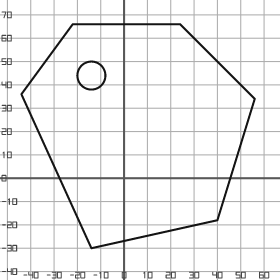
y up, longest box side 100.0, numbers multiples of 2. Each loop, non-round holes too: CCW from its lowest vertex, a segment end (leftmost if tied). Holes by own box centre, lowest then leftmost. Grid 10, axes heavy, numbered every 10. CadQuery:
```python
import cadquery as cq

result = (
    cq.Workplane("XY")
    .moveTo(-14.0, -30.0)
    .lineTo(40.0, -18.0)
    .lineTo(56.0, 34.0)
    .lineTo(24.0, 66.0)
    .lineTo(-22.0, 66.0)
    .lineTo(-44.0, 36.0)
    .close()
    .moveTo(-14.0, 44.0)
    .circle(6.0)
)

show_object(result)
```